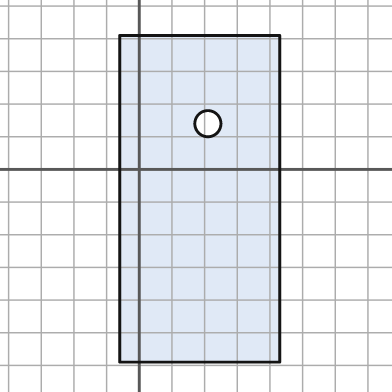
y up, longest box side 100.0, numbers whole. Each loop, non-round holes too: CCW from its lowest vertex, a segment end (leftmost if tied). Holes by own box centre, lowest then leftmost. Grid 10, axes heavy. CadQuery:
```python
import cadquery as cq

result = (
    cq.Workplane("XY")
    .moveTo(-6.0, -59.0)
    .lineTo(43.0, -59.0)
    .lineTo(43.0, 41.0)
    .lineTo(-6.0, 41.0)
    .close()
    .moveTo(21.0, 14.0)
    .circle(4.0)
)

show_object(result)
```